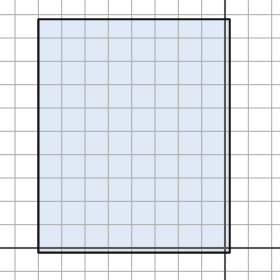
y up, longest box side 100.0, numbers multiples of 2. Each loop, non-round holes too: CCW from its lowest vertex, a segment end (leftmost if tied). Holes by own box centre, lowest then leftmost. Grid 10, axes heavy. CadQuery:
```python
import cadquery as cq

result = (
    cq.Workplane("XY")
    .moveTo(-80.0, -2.0)
    .lineTo(2.0, -2.0)
    .lineTo(2.0, 98.0)
    .lineTo(-80.0, 98.0)
    .close()
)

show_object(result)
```